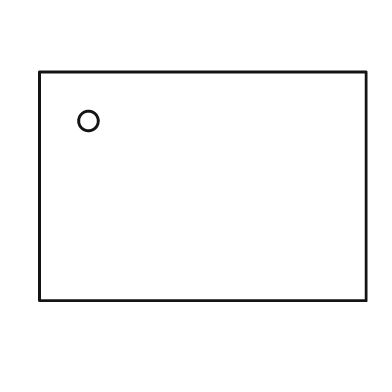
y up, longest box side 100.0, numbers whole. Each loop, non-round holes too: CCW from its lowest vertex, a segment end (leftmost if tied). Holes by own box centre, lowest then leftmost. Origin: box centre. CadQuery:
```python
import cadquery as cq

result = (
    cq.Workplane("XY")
    .moveTo(-50.0, -35.0)
    .lineTo(50.0, -35.0)
    .lineTo(50.0, 35.0)
    .lineTo(-50.0, 35.0)
    .close()
    .moveTo(-35.0, 20.0)
    .circle(3.0)
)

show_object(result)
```